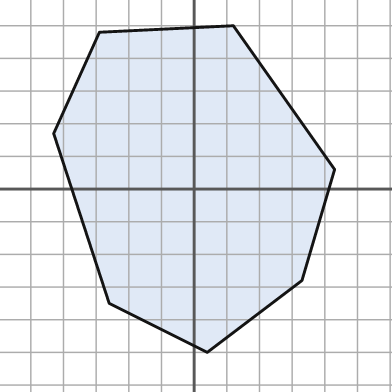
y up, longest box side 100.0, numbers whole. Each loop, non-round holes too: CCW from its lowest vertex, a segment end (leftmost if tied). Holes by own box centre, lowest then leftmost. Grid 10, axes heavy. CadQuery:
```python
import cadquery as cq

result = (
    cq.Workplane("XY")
    .moveTo(4.0, -50.0)
    .lineTo(33.0, -28.0)
    .lineTo(43.0, 6.0)
    .lineTo(12.0, 50.0)
    .lineTo(-29.0, 48.0)
    .lineTo(-43.0, 17.0)
    .lineTo(-26.0, -35.0)
    .close()
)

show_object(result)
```